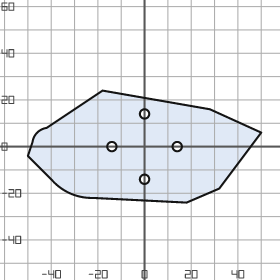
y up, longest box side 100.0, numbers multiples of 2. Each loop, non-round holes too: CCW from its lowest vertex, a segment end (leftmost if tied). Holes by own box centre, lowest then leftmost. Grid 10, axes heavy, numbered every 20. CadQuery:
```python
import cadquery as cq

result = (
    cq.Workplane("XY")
    .moveTo(18.0, -24.0)
    .lineTo(32.0, -18.0)
    .lineTo(50.0, 6.0)
    .lineTo(28.0, 16.0)
    .lineTo(-18.0, 24.0)
    .lineTo(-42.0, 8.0)
    .threePointArc((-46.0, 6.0), (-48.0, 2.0))
    .lineTo(-50.0, -4.0)
    .lineTo(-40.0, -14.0)
    .threePointArc((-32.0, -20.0), (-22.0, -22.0))
    .close()
    .moveTo(0.0, -14.0)
    .circle(2.0)
    .moveTo(-14.0, 0.0)
    .circle(2.0)
    .moveTo(14.0, 0.0)
    .circle(2.0)
    .moveTo(0.0, 14.0)
    .circle(2.0)
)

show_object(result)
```